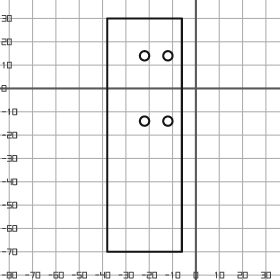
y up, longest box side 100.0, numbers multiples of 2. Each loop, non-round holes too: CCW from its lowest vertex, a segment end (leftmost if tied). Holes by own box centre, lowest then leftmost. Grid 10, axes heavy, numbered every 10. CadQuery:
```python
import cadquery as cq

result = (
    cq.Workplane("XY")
    .moveTo(-38.0, -70.0)
    .lineTo(-6.0, -70.0)
    .lineTo(-6.0, 30.0)
    .lineTo(-38.0, 30.0)
    .close()
    .moveTo(-22.0, -14.0)
    .circle(2.0)
    .moveTo(-12.0, -14.0)
    .circle(2.0)
    .moveTo(-22.0, 14.0)
    .circle(2.0)
    .moveTo(-12.0, 14.0)
    .circle(2.0)
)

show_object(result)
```